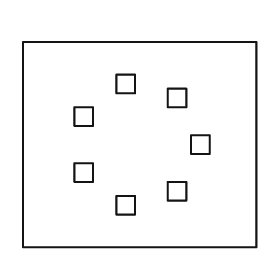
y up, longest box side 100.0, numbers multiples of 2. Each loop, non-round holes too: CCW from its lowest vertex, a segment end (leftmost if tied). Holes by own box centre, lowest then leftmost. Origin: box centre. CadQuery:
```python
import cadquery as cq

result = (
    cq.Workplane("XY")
    .moveTo(-50.0, -44.0)
    .lineTo(50.0, -44.0)
    .lineTo(50.0, 44.0)
    .lineTo(-50.0, 44.0)
    .close()
    .moveTo(-10.0, -30.0)
    .lineTo(-2.0, -30.0)
    .lineTo(-2.0, -22.0)
    .lineTo(-10.0, -22.0)
    .close()
    .moveTo(12.0, -24.0)
    .lineTo(20.0, -24.0)
    .lineTo(20.0, -16.0)
    .lineTo(12.0, -16.0)
    .close()
    .moveTo(-28.0, -16.0)
    .lineTo(-20.0, -16.0)
    .lineTo(-20.0, -8.0)
    .lineTo(-28.0, -8.0)
    .close()
    .moveTo(22.0, -4.0)
    .lineTo(30.0, -4.0)
    .lineTo(30.0, 4.0)
    .lineTo(22.0, 4.0)
    .close()
    .moveTo(-28.0, 8.0)
    .lineTo(-20.0, 8.0)
    .lineTo(-20.0, 16.0)
    .lineTo(-28.0, 16.0)
    .close()
    .moveTo(12.0, 16.0)
    .lineTo(20.0, 16.0)
    .lineTo(20.0, 24.0)
    .lineTo(12.0, 24.0)
    .close()
    .moveTo(-10.0, 22.0)
    .lineTo(-2.0, 22.0)
    .lineTo(-2.0, 30.0)
    .lineTo(-10.0, 30.0)
    .close()
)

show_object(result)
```